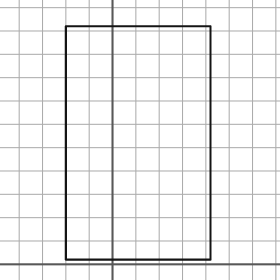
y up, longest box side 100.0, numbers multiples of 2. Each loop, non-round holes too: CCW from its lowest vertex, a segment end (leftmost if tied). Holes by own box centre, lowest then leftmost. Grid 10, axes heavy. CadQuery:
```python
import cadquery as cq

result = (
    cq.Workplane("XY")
    .moveTo(-20.0, 2.0)
    .lineTo(42.0, 2.0)
    .lineTo(42.0, 102.0)
    .lineTo(-20.0, 102.0)
    .close()
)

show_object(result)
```